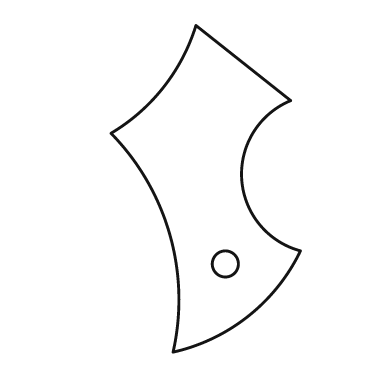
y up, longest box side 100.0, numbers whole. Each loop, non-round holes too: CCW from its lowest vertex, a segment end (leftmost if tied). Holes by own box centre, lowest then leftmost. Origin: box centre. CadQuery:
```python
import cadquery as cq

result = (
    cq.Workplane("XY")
    .moveTo(-10.0, -50.0)
    .threePointArc((13.0, -39.0), (29.0, -19.0))
    .threePointArc((11.0, 3.0), (26.0, 27.0))
    .lineTo(-3.0, 50.0)
    .threePointArc((-13.0, 31.0), (-29.0, 17.0))
    .threePointArc((-11.0, -14.0), (-10.0, -50.0))
    .close()
    .moveTo(6.0, -23.0)
    .circle(4.0)
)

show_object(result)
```